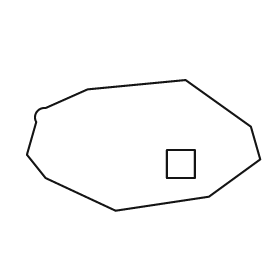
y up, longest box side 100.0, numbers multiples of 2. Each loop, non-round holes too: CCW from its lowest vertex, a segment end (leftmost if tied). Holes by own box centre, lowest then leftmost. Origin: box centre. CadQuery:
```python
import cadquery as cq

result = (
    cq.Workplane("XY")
    .moveTo(-12.0, -28.0)
    .lineTo(28.0, -22.0)
    .lineTo(50.0, -6.0)
    .lineTo(46.0, 8.0)
    .lineTo(18.0, 28.0)
    .lineTo(-24.0, 24.0)
    .lineTo(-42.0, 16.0)
    .threePointArc((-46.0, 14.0), (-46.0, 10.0))
    .lineTo(-50.0, -4.0)
    .lineTo(-42.0, -14.0)
    .close()
    .moveTo(10.0, -14.0)
    .lineTo(22.0, -14.0)
    .lineTo(22.0, -2.0)
    .lineTo(10.0, -2.0)
    .close()
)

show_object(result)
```